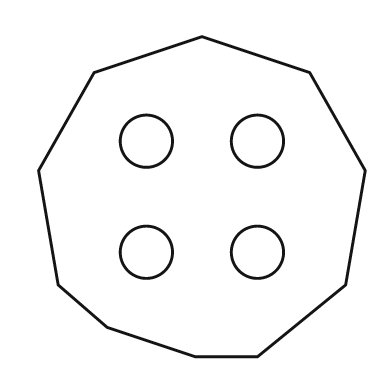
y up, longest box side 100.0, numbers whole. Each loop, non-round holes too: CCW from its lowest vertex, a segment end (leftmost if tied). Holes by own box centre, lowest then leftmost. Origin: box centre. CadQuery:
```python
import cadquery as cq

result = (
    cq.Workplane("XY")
    .moveTo(-2.0, -49.0)
    .lineTo(17.0, -49.0)
    .lineTo(44.0, -27.0)
    .lineTo(50.0, 8.0)
    .lineTo(33.0, 38.0)
    .lineTo(0.0, 49.0)
    .lineTo(-33.0, 38.0)
    .lineTo(-50.0, 8.0)
    .lineTo(-44.0, -27.0)
    .lineTo(-29.0, -40.0)
    .close()
    .moveTo(-17.0, -17.0)
    .circle(8.0)
    .moveTo(17.0, -17.0)
    .circle(8.0)
    .moveTo(-17.0, 17.0)
    .circle(8.0)
    .moveTo(17.0, 17.0)
    .circle(8.0)
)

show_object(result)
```